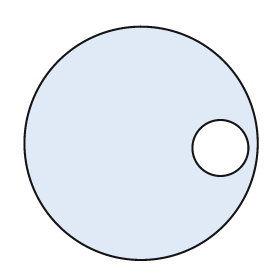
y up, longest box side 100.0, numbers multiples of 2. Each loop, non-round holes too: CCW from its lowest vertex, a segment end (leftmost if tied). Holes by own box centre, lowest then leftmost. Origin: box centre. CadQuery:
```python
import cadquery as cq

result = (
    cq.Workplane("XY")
    .moveTo(0.0, 0.0)
    .circle(50.0)
    .moveTo(34.0, -2.0)
    .circle(12.0)
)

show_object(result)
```